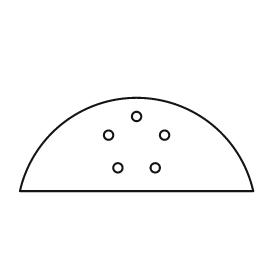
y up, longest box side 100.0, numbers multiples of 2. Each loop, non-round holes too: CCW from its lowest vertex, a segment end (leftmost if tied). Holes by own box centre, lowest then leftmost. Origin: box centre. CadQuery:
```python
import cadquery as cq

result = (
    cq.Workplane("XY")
    .moveTo(-50.0, -20.0)
    .lineTo(50.0, -20.0)
    .threePointArc((0.0, 20.0), (-50.0, -20.0))
    .close()
    .moveTo(-8.0, -10.0)
    .circle(2.0)
    .moveTo(8.0, -10.0)
    .circle(2.0)
    .moveTo(-12.0, 4.0)
    .circle(2.0)
    .moveTo(12.0, 4.0)
    .circle(2.0)
    .moveTo(0.0, 12.0)
    .circle(2.0)
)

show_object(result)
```